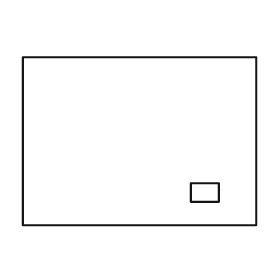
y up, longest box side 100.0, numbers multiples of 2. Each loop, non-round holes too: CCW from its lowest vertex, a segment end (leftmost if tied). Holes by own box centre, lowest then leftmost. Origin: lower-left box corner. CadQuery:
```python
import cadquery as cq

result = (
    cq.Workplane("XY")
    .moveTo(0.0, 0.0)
    .lineTo(100.0, 0.0)
    .lineTo(100.0, 72.0)
    .lineTo(0.0, 72.0)
    .close()
    .moveTo(72.0, 10.0)
    .lineTo(84.0, 10.0)
    .lineTo(84.0, 18.0)
    .lineTo(72.0, 18.0)
    .close()
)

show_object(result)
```